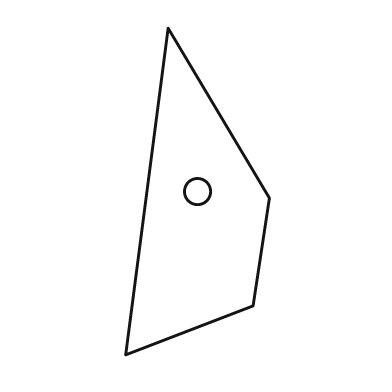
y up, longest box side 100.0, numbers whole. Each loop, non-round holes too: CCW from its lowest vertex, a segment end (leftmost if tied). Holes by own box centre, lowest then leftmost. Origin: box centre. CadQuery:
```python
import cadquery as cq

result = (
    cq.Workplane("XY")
    .moveTo(-22.0, -50.0)
    .lineTo(17.0, -35.0)
    .lineTo(22.0, -2.0)
    .lineTo(-9.0, 50.0)
    .close()
    .moveTo(0.0, 0.0)
    .circle(4.0)
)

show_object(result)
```